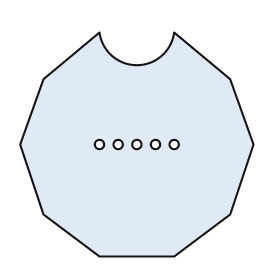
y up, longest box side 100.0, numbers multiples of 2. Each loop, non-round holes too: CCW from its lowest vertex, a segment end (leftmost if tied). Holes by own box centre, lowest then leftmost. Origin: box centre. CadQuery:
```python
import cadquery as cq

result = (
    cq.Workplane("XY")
    .moveTo(-16.0, -48.0)
    .lineTo(16.0, -48.0)
    .lineTo(40.0, -30.0)
    .lineTo(50.0, 0.0)
    .lineTo(40.0, 28.0)
    .lineTo(16.0, 48.0)
    .threePointArc((0.0, 34.0), (-16.0, 48.0))
    .lineTo(-40.0, 28.0)
    .lineTo(-50.0, 0.0)
    .lineTo(-40.0, -30.0)
    .close()
    .moveTo(-16.0, 0.0)
    .circle(2.0)
    .moveTo(-8.0, 0.0)
    .circle(2.0)
    .moveTo(0.0, 0.0)
    .circle(2.0)
    .moveTo(8.0, 0.0)
    .circle(2.0)
    .moveTo(16.0, 0.0)
    .circle(2.0)
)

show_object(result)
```